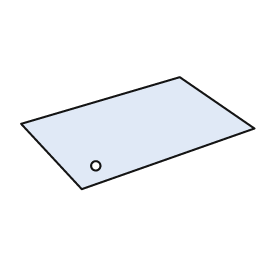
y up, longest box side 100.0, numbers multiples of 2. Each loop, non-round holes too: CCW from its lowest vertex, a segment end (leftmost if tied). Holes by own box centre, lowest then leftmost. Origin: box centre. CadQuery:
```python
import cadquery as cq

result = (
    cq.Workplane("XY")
    .moveTo(-24.0, -24.0)
    .lineTo(50.0, 2.0)
    .lineTo(18.0, 24.0)
    .lineTo(-50.0, 4.0)
    .close()
    .moveTo(-18.0, -14.0)
    .circle(2.0)
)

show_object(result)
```